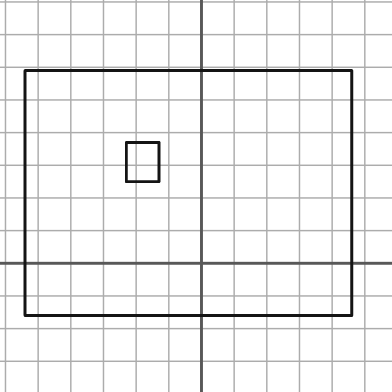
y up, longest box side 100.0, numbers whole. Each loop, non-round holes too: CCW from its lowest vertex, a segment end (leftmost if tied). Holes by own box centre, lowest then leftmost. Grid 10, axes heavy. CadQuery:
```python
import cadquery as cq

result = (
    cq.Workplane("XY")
    .moveTo(-54.0, -16.0)
    .lineTo(46.0, -16.0)
    .lineTo(46.0, 59.0)
    .lineTo(-54.0, 59.0)
    .close()
    .moveTo(-23.0, 25.0)
    .lineTo(-13.0, 25.0)
    .lineTo(-13.0, 37.0)
    .lineTo(-23.0, 37.0)
    .close()
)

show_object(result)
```